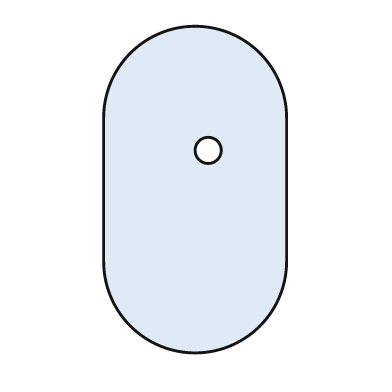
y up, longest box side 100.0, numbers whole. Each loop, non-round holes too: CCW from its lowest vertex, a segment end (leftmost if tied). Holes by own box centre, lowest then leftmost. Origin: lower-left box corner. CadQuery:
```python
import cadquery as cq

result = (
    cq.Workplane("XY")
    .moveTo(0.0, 28.0)
    .threePointArc((28.0, 0.0), (56.0, 28.0))
    .lineTo(56.0, 72.0)
    .threePointArc((28.0, 100.0), (0.0, 72.0))
    .close()
    .moveTo(32.0, 62.0)
    .circle(4.0)
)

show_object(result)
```